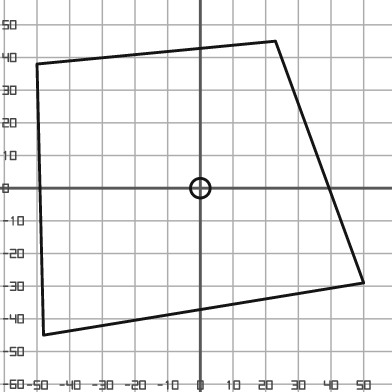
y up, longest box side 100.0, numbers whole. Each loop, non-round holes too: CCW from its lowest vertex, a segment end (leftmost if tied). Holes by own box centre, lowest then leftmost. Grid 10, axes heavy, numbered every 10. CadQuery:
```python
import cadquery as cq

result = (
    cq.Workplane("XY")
    .moveTo(-48.0, -45.0)
    .lineTo(50.0, -29.0)
    .lineTo(23.0, 45.0)
    .lineTo(-50.0, 38.0)
    .close()
    .moveTo(0.0, 0.0)
    .circle(3.0)
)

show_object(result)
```